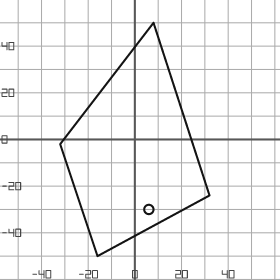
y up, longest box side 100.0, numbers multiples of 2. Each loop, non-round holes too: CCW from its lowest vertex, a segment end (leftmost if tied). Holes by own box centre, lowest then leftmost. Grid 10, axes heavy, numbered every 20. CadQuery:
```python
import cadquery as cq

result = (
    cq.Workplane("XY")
    .moveTo(-16.0, -50.0)
    .lineTo(32.0, -24.0)
    .lineTo(8.0, 50.0)
    .lineTo(-32.0, -2.0)
    .close()
    .moveTo(6.0, -30.0)
    .circle(2.0)
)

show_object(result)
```